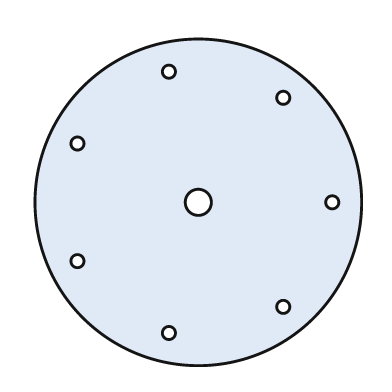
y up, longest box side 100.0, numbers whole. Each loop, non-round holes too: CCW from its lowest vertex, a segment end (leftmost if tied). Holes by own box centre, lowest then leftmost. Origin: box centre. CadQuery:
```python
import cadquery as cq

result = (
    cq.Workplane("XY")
    .moveTo(0.0, 0.0)
    .circle(50.0)
    .moveTo(-9.0, -40.0)
    .circle(2.0)
    .moveTo(26.0, -32.0)
    .circle(2.0)
    .moveTo(-37.0, -18.0)
    .circle(2.0)
    .moveTo(0.0, 0.0)
    .circle(4.0)
    .moveTo(41.0, 0.0)
    .circle(2.0)
    .moveTo(-37.0, 18.0)
    .circle(2.0)
    .moveTo(26.0, 32.0)
    .circle(2.0)
    .moveTo(-9.0, 40.0)
    .circle(2.0)
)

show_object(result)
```